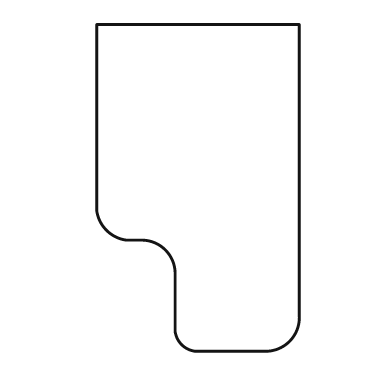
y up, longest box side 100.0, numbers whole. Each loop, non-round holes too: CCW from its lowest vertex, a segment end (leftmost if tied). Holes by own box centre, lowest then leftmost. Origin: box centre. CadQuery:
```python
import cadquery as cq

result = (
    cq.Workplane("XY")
    .moveTo(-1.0, -50.0)
    .lineTo(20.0, -50.0)
    .threePointArc((28.0, -47.0), (31.0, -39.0))
    .lineTo(31.0, 50.0)
    .lineTo(-31.0, 50.0)
    .lineTo(-31.0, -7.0)
    .threePointArc((-28.0, -13.0), (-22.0, -16.0))
    .lineTo(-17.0, -16.0)
    .threePointArc((-10.0, -19.0), (-7.0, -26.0))
    .lineTo(-7.0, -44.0)
    .threePointArc((-5.0, -48.0), (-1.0, -50.0))
    .close()
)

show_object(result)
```